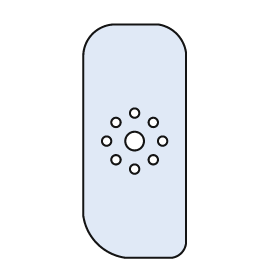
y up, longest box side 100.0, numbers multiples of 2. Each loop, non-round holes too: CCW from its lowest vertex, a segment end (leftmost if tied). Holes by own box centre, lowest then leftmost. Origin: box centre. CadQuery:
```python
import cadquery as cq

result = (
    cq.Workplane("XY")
    .moveTo(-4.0, -50.0)
    .lineTo(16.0, -50.0)
    .threePointArc((20.0, -48.0), (22.0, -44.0))
    .lineTo(22.0, 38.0)
    .threePointArc((18.0, 46.0), (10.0, 50.0))
    .lineTo(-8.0, 50.0)
    .threePointArc((-18.0, 46.0), (-22.0, 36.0))
    .lineTo(-22.0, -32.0)
    .threePointArc((-16.0, -44.0), (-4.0, -50.0))
    .close()
    .moveTo(0.0, -12.0)
    .circle(2.0)
    .moveTo(-8.0, -8.0)
    .circle(2.0)
    .moveTo(8.0, -8.0)
    .circle(2.0)
    .moveTo(-12.0, 0.0)
    .circle(2.0)
    .moveTo(0.0, 0.0)
    .circle(4.0)
    .moveTo(12.0, 0.0)
    .circle(2.0)
    .moveTo(-8.0, 8.0)
    .circle(2.0)
    .moveTo(8.0, 8.0)
    .circle(2.0)
    .moveTo(0.0, 12.0)
    .circle(2.0)
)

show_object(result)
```